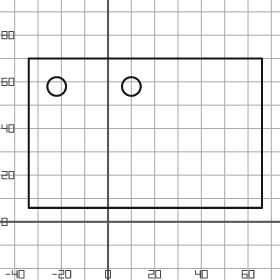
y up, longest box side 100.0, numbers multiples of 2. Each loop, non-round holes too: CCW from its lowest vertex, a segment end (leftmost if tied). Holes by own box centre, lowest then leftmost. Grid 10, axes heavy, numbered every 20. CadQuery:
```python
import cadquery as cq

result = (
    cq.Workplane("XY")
    .moveTo(-34.0, 6.0)
    .lineTo(66.0, 6.0)
    .lineTo(66.0, 70.0)
    .lineTo(-34.0, 70.0)
    .close()
    .moveTo(-22.0, 58.0)
    .circle(4.0)
    .moveTo(10.0, 58.0)
    .circle(4.0)
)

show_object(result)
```